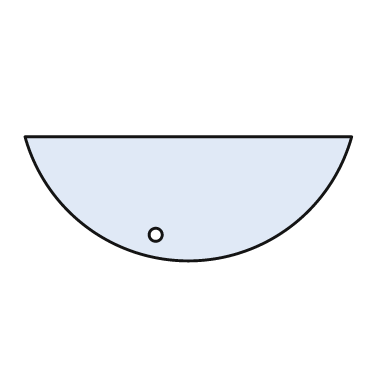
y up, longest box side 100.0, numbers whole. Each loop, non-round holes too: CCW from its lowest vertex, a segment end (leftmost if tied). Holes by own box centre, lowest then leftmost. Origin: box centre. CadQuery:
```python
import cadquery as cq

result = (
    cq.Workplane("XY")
    .moveTo(-50.0, 19.0)
    .threePointArc((0.0, -19.0), (50.0, 19.0))
    .close()
    .moveTo(-10.0, -11.0)
    .circle(2.0)
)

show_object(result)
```